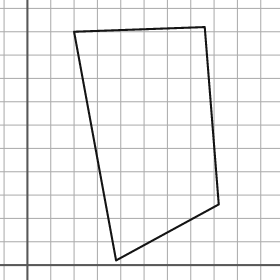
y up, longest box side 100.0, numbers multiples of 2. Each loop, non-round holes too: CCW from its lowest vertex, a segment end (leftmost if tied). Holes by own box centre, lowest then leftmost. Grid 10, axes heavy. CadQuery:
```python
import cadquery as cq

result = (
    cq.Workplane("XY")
    .moveTo(38.0, 2.0)
    .lineTo(82.0, 26.0)
    .lineTo(76.0, 102.0)
    .lineTo(20.0, 100.0)
    .close()
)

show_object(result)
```